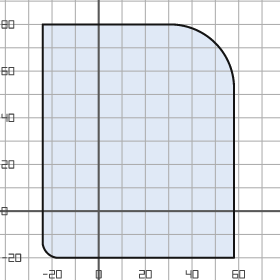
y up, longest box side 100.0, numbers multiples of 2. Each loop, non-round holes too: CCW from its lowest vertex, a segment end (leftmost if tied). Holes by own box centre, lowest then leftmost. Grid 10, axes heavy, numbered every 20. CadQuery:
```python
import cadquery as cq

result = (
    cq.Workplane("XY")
    .moveTo(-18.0, -20.0)
    .lineTo(58.0, -20.0)
    .lineTo(58.0, 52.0)
    .threePointArc((50.0, 72.0), (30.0, 80.0))
    .lineTo(-24.0, 80.0)
    .lineTo(-24.0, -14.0)
    .threePointArc((-22.0, -18.0), (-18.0, -20.0))
    .close()
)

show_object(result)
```